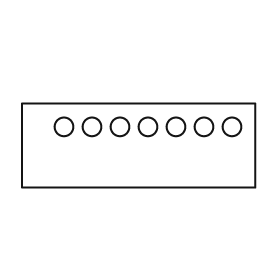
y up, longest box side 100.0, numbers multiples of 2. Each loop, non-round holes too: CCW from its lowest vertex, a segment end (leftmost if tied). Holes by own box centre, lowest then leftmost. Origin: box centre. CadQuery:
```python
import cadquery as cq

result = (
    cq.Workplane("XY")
    .moveTo(-50.0, -18.0)
    .lineTo(50.0, -18.0)
    .lineTo(50.0, 18.0)
    .lineTo(-50.0, 18.0)
    .close()
    .moveTo(-32.0, 8.0)
    .circle(4.0)
    .moveTo(-20.0, 8.0)
    .circle(4.0)
    .moveTo(-8.0, 8.0)
    .circle(4.0)
    .moveTo(4.0, 8.0)
    .circle(4.0)
    .moveTo(16.0, 8.0)
    .circle(4.0)
    .moveTo(28.0, 8.0)
    .circle(4.0)
    .moveTo(40.0, 8.0)
    .circle(4.0)
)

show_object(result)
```